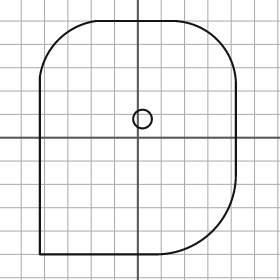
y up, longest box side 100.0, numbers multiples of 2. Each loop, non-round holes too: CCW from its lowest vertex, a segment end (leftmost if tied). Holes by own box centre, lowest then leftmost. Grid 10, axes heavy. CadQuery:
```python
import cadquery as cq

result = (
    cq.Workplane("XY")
    .moveTo(-42.0, -50.0)
    .lineTo(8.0, -50.0)
    .threePointArc((32.0, -40.0), (42.0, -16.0))
    .lineTo(42.0, 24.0)
    .threePointArc((34.0, 42.0), (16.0, 50.0))
    .lineTo(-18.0, 50.0)
    .threePointArc((-34.0, 42.0), (-42.0, 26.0))
    .close()
    .moveTo(2.0, 8.0)
    .circle(4.0)
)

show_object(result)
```